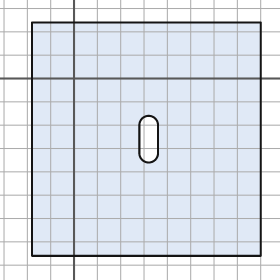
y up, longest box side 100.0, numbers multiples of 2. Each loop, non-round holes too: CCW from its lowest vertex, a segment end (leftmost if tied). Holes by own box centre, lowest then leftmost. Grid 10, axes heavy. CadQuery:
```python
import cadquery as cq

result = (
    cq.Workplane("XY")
    .moveTo(-18.0, -76.0)
    .lineTo(80.0, -76.0)
    .lineTo(80.0, 24.0)
    .lineTo(-18.0, 24.0)
    .close()
    .moveTo(28.0, -32.0)
    .threePointArc((32.0, -36.0), (36.0, -32.0))
    .lineTo(36.0, -20.0)
    .threePointArc((32.0, -16.0), (28.0, -20.0))
    .close()
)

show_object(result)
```